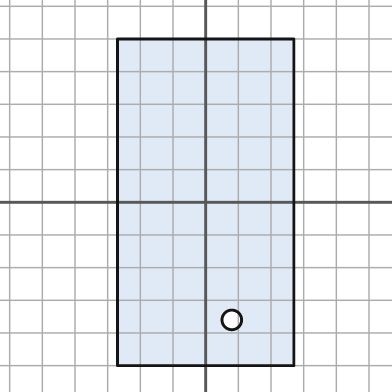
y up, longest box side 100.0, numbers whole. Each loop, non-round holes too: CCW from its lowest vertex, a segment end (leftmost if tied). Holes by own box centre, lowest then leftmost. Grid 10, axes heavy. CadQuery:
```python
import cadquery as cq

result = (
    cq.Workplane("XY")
    .moveTo(-27.0, -50.0)
    .lineTo(27.0, -50.0)
    .lineTo(27.0, 50.0)
    .lineTo(-27.0, 50.0)
    .close()
    .moveTo(8.0, -36.0)
    .circle(3.0)
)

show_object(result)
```